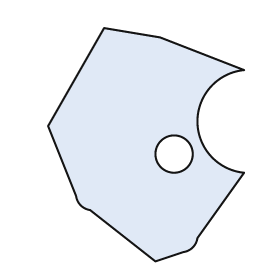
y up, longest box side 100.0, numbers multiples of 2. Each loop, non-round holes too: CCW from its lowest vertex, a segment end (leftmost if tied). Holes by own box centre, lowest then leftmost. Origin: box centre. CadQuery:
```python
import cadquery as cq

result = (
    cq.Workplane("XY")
    .moveTo(4.0, -50.0)
    .lineTo(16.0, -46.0)
    .threePointArc((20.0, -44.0), (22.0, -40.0))
    .lineTo(42.0, -12.0)
    .threePointArc((22.0, 10.0), (42.0, 32.0))
    .lineTo(6.0, 46.0)
    .lineTo(-18.0, 50.0)
    .lineTo(-42.0, 8.0)
    .lineTo(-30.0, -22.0)
    .threePointArc((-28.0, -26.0), (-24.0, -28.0))
    .close()
    .moveTo(12.0, -4.0)
    .circle(8.0)
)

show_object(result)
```